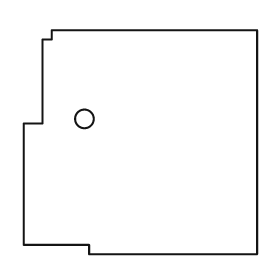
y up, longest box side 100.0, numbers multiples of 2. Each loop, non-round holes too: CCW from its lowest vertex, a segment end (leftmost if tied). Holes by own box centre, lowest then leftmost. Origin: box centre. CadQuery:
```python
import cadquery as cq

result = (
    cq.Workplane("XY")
    .moveTo(-22.0, -48.0)
    .lineTo(50.0, -48.0)
    .lineTo(50.0, 48.0)
    .lineTo(-38.0, 48.0)
    .lineTo(-38.0, 44.0)
    .lineTo(-42.0, 44.0)
    .lineTo(-42.0, 8.0)
    .lineTo(-50.0, 8.0)
    .lineTo(-50.0, -44.0)
    .lineTo(-22.0, -44.0)
    .close()
    .moveTo(-24.0, 10.0)
    .circle(4.0)
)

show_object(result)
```